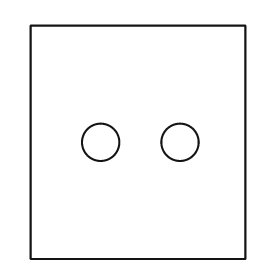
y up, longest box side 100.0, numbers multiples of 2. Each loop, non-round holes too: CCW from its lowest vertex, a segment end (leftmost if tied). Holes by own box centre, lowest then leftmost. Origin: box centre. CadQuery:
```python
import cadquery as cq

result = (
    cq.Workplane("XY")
    .moveTo(-46.0, -50.0)
    .lineTo(46.0, -50.0)
    .lineTo(46.0, 50.0)
    .lineTo(-46.0, 50.0)
    .close()
    .moveTo(-16.0, 0.0)
    .circle(8.0)
    .moveTo(18.0, 0.0)
    .circle(8.0)
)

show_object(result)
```